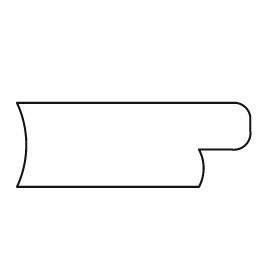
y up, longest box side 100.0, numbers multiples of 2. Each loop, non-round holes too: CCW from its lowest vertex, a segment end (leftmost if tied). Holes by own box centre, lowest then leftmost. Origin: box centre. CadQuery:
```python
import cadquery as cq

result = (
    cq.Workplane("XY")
    .moveTo(-50.0, -18.0)
    .lineTo(28.0, -18.0)
    .threePointArc((30.0, -10.0), (28.0, -2.0))
    .lineTo(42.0, -2.0)
    .threePointArc((48.0, 0.0), (50.0, 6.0))
    .lineTo(50.0, 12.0)
    .threePointArc((48.0, 16.0), (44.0, 18.0))
    .lineTo(-50.0, 18.0)
    .threePointArc((-46.0, 0.0), (-50.0, -18.0))
    .close()
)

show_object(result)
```